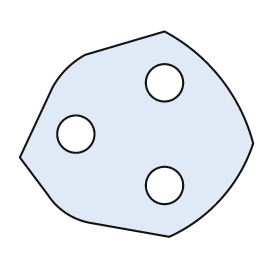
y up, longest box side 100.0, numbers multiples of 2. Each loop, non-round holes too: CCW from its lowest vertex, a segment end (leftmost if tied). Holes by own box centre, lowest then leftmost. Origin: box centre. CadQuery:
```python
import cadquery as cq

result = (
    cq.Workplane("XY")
    .moveTo(14.0, -44.0)
    .threePointArc((36.0, -28.0), (50.0, -4.0))
    .threePointArc((36.0, 24.0), (12.0, 44.0))
    .lineTo(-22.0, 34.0)
    .threePointArc((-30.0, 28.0), (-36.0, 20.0))
    .lineTo(-50.0, -10.0)
    .lineTo(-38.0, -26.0)
    .threePointArc((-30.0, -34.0), (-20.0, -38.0))
    .close()
    .moveTo(12.0, -22.0)
    .circle(8.0)
    .moveTo(-26.0, 0.0)
    .circle(8.0)
    .moveTo(12.0, 22.0)
    .circle(8.0)
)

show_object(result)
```